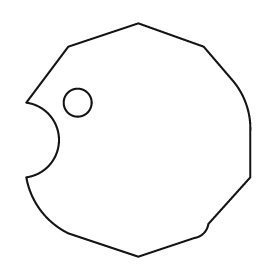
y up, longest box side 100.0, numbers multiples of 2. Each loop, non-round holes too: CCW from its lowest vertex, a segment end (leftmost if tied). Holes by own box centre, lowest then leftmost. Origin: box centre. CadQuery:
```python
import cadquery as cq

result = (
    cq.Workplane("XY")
    .moveTo(0.0, -50.0)
    .lineTo(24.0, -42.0)
    .threePointArc((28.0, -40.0), (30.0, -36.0))
    .lineTo(48.0, -16.0)
    .lineTo(48.0, 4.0)
    .threePointArc((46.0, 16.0), (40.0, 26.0))
    .lineTo(28.0, 40.0)
    .lineTo(0.0, 50.0)
    .lineTo(-30.0, 40.0)
    .lineTo(-48.0, 16.0)
    .threePointArc((-34.0, 0.0), (-48.0, -16.0))
    .threePointArc((-42.0, -30.0), (-30.0, -40.0))
    .close()
    .moveTo(-26.0, 16.0)
    .circle(6.0)
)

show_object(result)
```